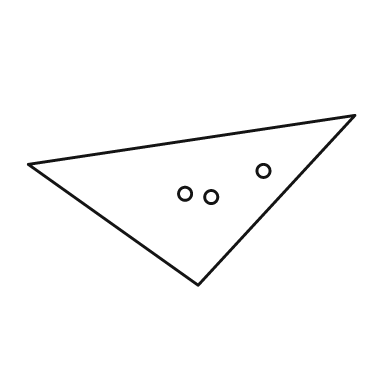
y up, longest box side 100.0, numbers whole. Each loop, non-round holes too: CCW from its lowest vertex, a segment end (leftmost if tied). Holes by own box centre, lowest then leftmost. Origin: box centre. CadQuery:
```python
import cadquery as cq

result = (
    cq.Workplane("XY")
    .moveTo(2.0, -26.0)
    .lineTo(50.0, 26.0)
    .lineTo(-50.0, 11.0)
    .close()
    .moveTo(6.0, 1.0)
    .circle(2.0)
    .moveTo(-2.0, 2.0)
    .circle(2.0)
    .moveTo(22.0, 9.0)
    .circle(2.0)
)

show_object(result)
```